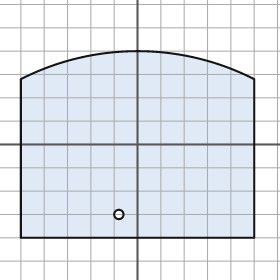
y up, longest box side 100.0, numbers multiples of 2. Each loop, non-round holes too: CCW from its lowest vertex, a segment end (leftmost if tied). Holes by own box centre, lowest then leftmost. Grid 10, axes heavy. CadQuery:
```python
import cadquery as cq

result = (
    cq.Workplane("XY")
    .moveTo(-50.0, -40.0)
    .lineTo(50.0, -40.0)
    .lineTo(50.0, 28.0)
    .threePointArc((0.0, 40.0), (-50.0, 28.0))
    .close()
    .moveTo(-8.0, -30.0)
    .circle(2.0)
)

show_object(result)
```